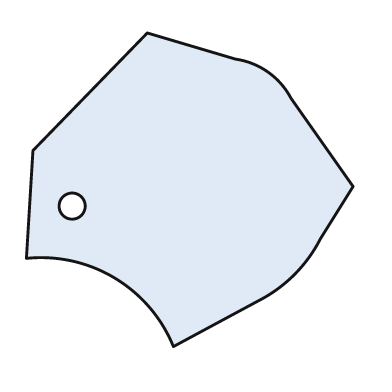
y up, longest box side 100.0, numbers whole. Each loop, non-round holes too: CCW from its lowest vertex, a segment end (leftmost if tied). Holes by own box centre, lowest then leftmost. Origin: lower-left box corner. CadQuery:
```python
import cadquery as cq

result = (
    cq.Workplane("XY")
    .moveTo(45.0, 0.0)
    .lineTo(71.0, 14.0)
    .threePointArc((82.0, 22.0), (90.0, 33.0))
    .lineTo(100.0, 49.0)
    .lineTo(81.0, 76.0)
    .threePointArc((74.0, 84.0), (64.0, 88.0))
    .lineTo(37.0, 96.0)
    .lineTo(2.0, 60.0)
    .lineTo(0.0, 27.0)
    .threePointArc((27.0, 21.0), (45.0, 0.0))
    .close()
    .moveTo(14.0, 43.0)
    .circle(4.0)
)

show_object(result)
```